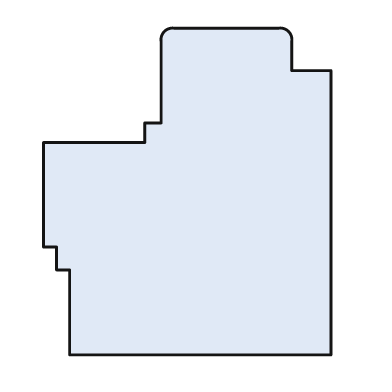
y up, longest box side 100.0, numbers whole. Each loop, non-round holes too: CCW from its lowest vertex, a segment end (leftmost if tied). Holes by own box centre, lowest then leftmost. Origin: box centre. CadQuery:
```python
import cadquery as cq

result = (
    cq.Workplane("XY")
    .moveTo(-36.0, -50.0)
    .lineTo(44.0, -50.0)
    .lineTo(44.0, 37.0)
    .lineTo(32.0, 37.0)
    .lineTo(32.0, 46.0)
    .threePointArc((31.0, 49.0), (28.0, 50.0))
    .lineTo(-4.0, 50.0)
    .threePointArc((-7.0, 49.0), (-8.0, 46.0))
    .lineTo(-8.0, 21.0)
    .lineTo(-13.0, 21.0)
    .lineTo(-13.0, 15.0)
    .lineTo(-44.0, 15.0)
    .lineTo(-44.0, -17.0)
    .lineTo(-40.0, -17.0)
    .lineTo(-40.0, -24.0)
    .lineTo(-36.0, -24.0)
    .close()
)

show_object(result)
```